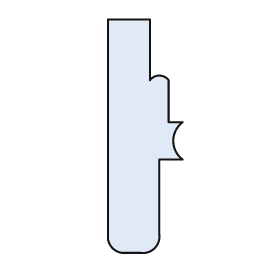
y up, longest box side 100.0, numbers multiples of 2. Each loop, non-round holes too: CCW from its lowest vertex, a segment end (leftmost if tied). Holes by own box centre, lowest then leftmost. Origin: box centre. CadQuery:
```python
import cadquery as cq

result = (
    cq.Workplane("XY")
    .moveTo(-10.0, -50.0)
    .lineTo(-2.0, -50.0)
    .threePointArc((4.0, -48.0), (6.0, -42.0))
    .lineTo(6.0, -10.0)
    .lineTo(16.0, -10.0)
    .threePointArc((12.0, -2.0), (16.0, 6.0))
    .lineTo(10.0, 6.0)
    .lineTo(10.0, 24.0)
    .threePointArc((6.0, 26.0), (2.0, 24.0))
    .lineTo(2.0, 50.0)
    .lineTo(-16.0, 50.0)
    .lineTo(-16.0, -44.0)
    .threePointArc((-14.0, -48.0), (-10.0, -50.0))
    .close()
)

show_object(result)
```